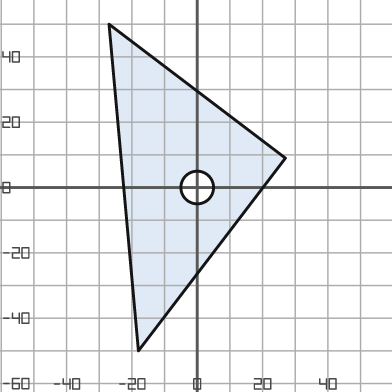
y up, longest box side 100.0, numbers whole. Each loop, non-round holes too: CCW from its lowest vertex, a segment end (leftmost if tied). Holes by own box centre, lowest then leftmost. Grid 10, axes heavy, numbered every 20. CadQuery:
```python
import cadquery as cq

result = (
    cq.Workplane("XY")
    .moveTo(-18.0, -50.0)
    .lineTo(27.0, 9.0)
    .lineTo(-27.0, 50.0)
    .close()
    .moveTo(0.0, 0.0)
    .circle(5.0)
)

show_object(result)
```